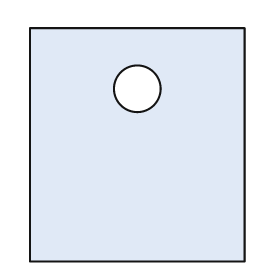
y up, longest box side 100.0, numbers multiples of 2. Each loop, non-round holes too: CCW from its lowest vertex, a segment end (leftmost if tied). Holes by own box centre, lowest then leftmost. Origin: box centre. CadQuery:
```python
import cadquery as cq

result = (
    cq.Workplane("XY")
    .moveTo(-46.0, -50.0)
    .lineTo(46.0, -50.0)
    .lineTo(46.0, 50.0)
    .lineTo(-46.0, 50.0)
    .close()
    .moveTo(0.0, 24.0)
    .circle(10.0)
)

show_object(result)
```